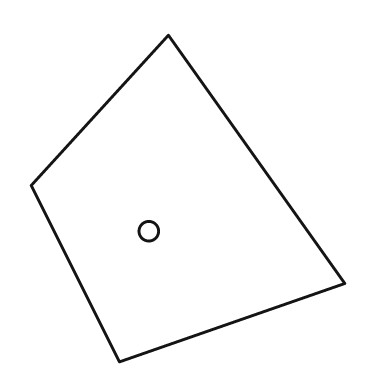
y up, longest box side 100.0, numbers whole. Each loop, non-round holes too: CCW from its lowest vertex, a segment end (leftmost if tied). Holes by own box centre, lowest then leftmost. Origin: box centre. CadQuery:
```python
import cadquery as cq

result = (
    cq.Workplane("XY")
    .moveTo(-21.0, -50.0)
    .lineTo(48.0, -26.0)
    .lineTo(-6.0, 50.0)
    .lineTo(-48.0, 4.0)
    .close()
    .moveTo(-12.0, -10.0)
    .circle(3.0)
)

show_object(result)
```